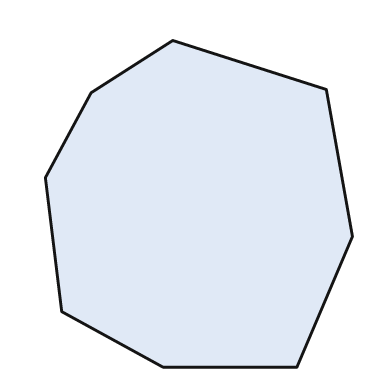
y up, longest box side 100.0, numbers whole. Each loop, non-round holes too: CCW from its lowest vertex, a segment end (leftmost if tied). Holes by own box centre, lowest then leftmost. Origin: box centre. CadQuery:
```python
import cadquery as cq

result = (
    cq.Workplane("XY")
    .moveTo(-11.0, -50.0)
    .lineTo(30.0, -50.0)
    .lineTo(47.0, -10.0)
    .lineTo(39.0, 35.0)
    .lineTo(-8.0, 50.0)
    .lineTo(-33.0, 34.0)
    .lineTo(-47.0, 8.0)
    .lineTo(-42.0, -33.0)
    .close()
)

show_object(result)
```